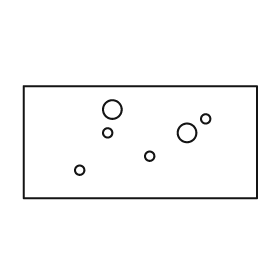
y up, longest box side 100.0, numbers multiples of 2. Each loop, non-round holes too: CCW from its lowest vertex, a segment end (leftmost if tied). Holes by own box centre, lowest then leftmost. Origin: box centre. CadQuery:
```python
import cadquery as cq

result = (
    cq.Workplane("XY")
    .moveTo(-50.0, -24.0)
    .lineTo(50.0, -24.0)
    .lineTo(50.0, 24.0)
    .lineTo(-50.0, 24.0)
    .close()
    .moveTo(-26.0, -12.0)
    .circle(2.0)
    .moveTo(4.0, -6.0)
    .circle(2.0)
    .moveTo(-14.0, 4.0)
    .circle(2.0)
    .moveTo(20.0, 4.0)
    .circle(4.0)
    .moveTo(28.0, 10.0)
    .circle(2.0)
    .moveTo(-12.0, 14.0)
    .circle(4.0)
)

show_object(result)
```